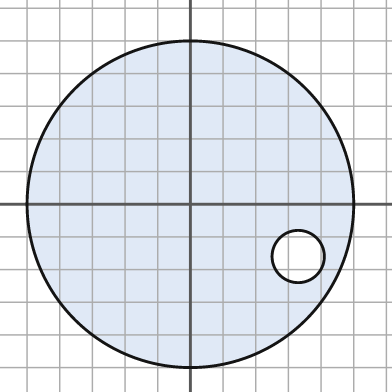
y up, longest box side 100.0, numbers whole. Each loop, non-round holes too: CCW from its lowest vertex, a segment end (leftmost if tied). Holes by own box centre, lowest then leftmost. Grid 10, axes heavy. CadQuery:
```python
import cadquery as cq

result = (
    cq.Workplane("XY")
    .moveTo(0.0, 0.0)
    .circle(50.0)
    .moveTo(33.0, -16.0)
    .circle(8.0)
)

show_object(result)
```